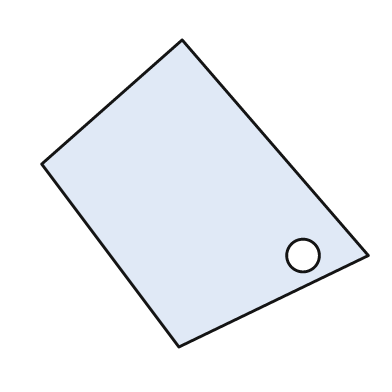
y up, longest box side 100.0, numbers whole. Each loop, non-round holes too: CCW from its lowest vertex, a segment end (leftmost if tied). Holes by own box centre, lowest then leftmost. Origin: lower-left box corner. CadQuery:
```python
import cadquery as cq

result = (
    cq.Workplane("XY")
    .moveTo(42.0, 0.0)
    .lineTo(100.0, 28.0)
    .lineTo(43.0, 94.0)
    .lineTo(0.0, 56.0)
    .close()
    .moveTo(80.0, 28.0)
    .circle(5.0)
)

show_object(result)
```